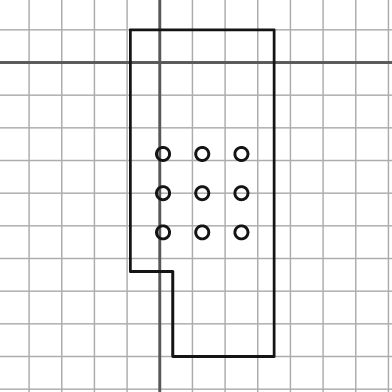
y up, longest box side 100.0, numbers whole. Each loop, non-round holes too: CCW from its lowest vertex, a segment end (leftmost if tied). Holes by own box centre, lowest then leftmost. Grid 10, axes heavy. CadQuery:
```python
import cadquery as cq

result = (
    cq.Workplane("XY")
    .moveTo(4.0, -90.0)
    .lineTo(35.0, -90.0)
    .lineTo(35.0, 10.0)
    .lineTo(-9.0, 10.0)
    .lineTo(-9.0, -64.0)
    .lineTo(4.0, -64.0)
    .close()
    .moveTo(1.0, -52.0)
    .circle(2.0)
    .moveTo(13.0, -52.0)
    .circle(2.0)
    .moveTo(25.0, -52.0)
    .circle(2.0)
    .moveTo(1.0, -40.0)
    .circle(2.0)
    .moveTo(13.0, -40.0)
    .circle(2.0)
    .moveTo(25.0, -40.0)
    .circle(2.0)
    .moveTo(1.0, -28.0)
    .circle(2.0)
    .moveTo(13.0, -28.0)
    .circle(2.0)
    .moveTo(25.0, -28.0)
    .circle(2.0)
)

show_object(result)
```